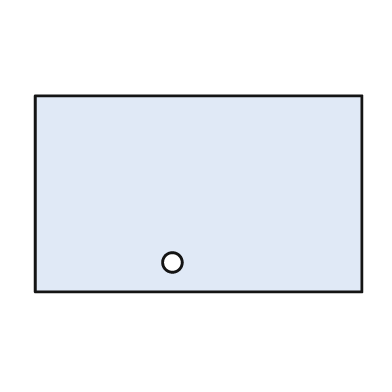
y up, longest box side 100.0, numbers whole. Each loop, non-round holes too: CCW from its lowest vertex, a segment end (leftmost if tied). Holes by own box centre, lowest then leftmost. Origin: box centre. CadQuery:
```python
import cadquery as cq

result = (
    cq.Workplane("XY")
    .moveTo(-50.0, -30.0)
    .lineTo(50.0, -30.0)
    .lineTo(50.0, 30.0)
    .lineTo(-50.0, 30.0)
    .close()
    .moveTo(-8.0, -21.0)
    .circle(3.0)
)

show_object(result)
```